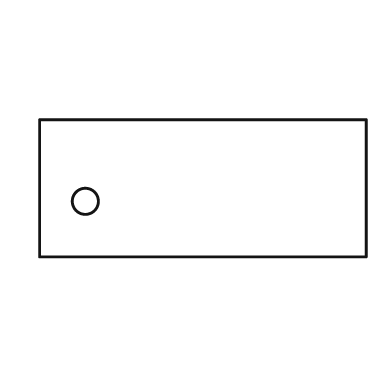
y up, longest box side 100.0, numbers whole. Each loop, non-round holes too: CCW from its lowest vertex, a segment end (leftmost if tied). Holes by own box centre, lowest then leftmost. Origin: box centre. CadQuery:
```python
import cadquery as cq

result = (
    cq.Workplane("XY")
    .moveTo(-50.0, -21.0)
    .lineTo(50.0, -21.0)
    .lineTo(50.0, 21.0)
    .lineTo(-50.0, 21.0)
    .close()
    .moveTo(-36.0, -4.0)
    .circle(4.0)
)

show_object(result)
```